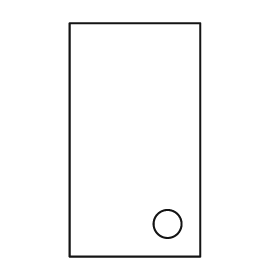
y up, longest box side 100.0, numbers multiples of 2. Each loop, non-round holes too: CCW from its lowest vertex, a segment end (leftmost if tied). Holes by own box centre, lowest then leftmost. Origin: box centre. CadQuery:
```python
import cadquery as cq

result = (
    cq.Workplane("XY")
    .moveTo(-28.0, -50.0)
    .lineTo(28.0, -50.0)
    .lineTo(28.0, 50.0)
    .lineTo(-28.0, 50.0)
    .close()
    .moveTo(14.0, -36.0)
    .circle(6.0)
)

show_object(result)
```